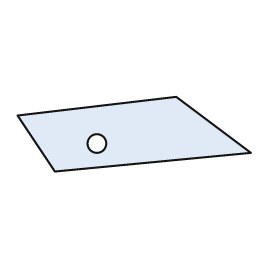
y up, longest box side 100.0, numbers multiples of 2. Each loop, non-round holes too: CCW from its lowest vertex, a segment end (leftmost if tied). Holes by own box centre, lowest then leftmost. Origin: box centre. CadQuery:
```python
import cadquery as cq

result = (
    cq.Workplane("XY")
    .moveTo(-34.0, -16.0)
    .lineTo(50.0, -8.0)
    .lineTo(18.0, 16.0)
    .lineTo(-50.0, 8.0)
    .close()
    .moveTo(-16.0, -4.0)
    .circle(4.0)
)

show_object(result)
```